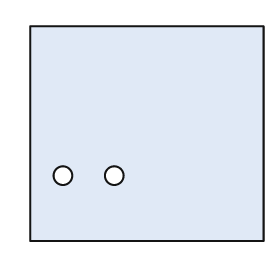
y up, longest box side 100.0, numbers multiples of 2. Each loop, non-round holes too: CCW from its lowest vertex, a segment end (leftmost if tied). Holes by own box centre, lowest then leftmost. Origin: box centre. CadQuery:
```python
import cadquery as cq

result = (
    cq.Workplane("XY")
    .moveTo(-50.0, -46.0)
    .lineTo(50.0, -46.0)
    .lineTo(50.0, 46.0)
    .lineTo(-50.0, 46.0)
    .close()
    .moveTo(-36.0, -18.0)
    .circle(4.0)
    .moveTo(-14.0, -18.0)
    .circle(4.0)
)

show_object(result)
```